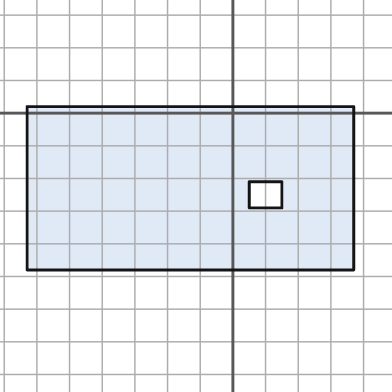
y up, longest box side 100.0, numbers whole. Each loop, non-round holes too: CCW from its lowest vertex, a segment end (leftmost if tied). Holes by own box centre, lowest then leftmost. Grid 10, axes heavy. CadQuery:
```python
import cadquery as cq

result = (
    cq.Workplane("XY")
    .moveTo(-63.0, -48.0)
    .lineTo(37.0, -48.0)
    .lineTo(37.0, 2.0)
    .lineTo(-63.0, 2.0)
    .close()
    .moveTo(5.0, -29.0)
    .lineTo(15.0, -29.0)
    .lineTo(15.0, -21.0)
    .lineTo(5.0, -21.0)
    .close()
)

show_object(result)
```